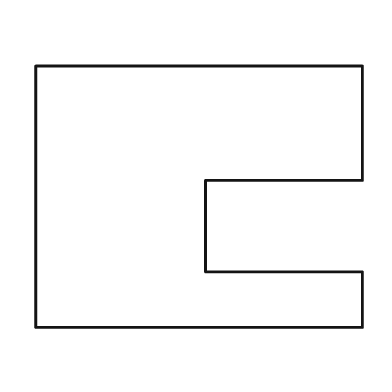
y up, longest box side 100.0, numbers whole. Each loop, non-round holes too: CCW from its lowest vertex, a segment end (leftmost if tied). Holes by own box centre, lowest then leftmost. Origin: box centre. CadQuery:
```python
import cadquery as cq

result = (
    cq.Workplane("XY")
    .moveTo(-50.0, -40.0)
    .lineTo(50.0, -40.0)
    .lineTo(50.0, -23.0)
    .lineTo(2.0, -23.0)
    .lineTo(2.0, 5.0)
    .lineTo(50.0, 5.0)
    .lineTo(50.0, 40.0)
    .lineTo(-50.0, 40.0)
    .close()
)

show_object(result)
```